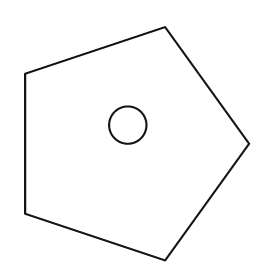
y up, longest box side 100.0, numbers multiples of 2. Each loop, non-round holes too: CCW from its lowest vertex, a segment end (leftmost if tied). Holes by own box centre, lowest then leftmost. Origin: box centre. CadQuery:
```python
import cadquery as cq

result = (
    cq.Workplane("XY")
    .moveTo(12.0, -50.0)
    .lineTo(48.0, 0.0)
    .lineTo(12.0, 50.0)
    .lineTo(-48.0, 30.0)
    .lineTo(-48.0, -30.0)
    .close()
    .moveTo(-4.0, 8.0)
    .circle(8.0)
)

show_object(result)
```